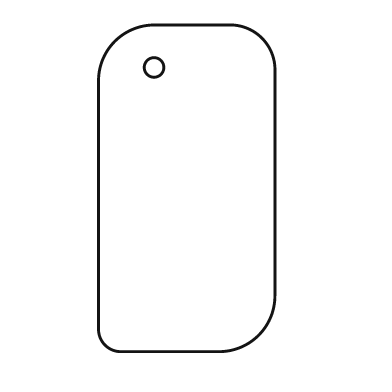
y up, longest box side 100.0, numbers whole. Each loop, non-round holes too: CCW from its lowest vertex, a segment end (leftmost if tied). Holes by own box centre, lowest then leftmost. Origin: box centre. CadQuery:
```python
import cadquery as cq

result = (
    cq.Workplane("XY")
    .moveTo(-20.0, -50.0)
    .lineTo(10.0, -50.0)
    .threePointArc((22.0, -45.0), (27.0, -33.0))
    .lineTo(27.0, 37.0)
    .threePointArc((23.0, 46.0), (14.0, 50.0))
    .lineTo(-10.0, 50.0)
    .threePointArc((-22.0, 45.0), (-27.0, 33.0))
    .lineTo(-27.0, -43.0)
    .threePointArc((-25.0, -48.0), (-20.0, -50.0))
    .close()
    .moveTo(-10.0, 37.0)
    .circle(3.0)
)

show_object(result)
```